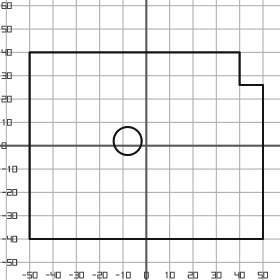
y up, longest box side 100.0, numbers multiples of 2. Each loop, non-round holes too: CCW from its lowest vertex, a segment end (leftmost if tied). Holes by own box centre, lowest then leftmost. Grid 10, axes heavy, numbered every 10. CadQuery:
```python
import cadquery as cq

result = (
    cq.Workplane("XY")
    .moveTo(-50.0, -40.0)
    .lineTo(50.0, -40.0)
    .lineTo(50.0, 26.0)
    .lineTo(40.0, 26.0)
    .lineTo(40.0, 40.0)
    .lineTo(-50.0, 40.0)
    .close()
    .moveTo(-8.0, 2.0)
    .circle(6.0)
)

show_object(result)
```